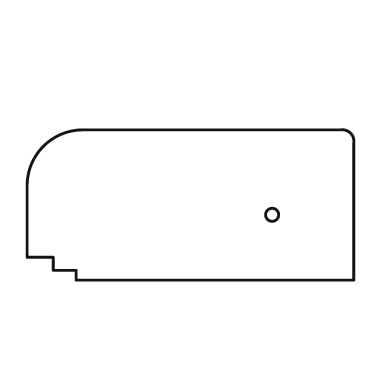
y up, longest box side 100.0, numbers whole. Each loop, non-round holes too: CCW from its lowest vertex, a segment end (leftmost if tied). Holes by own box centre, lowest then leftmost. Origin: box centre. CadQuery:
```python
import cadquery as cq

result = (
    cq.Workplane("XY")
    .moveTo(-35.0, -23.0)
    .lineTo(50.0, -23.0)
    .lineTo(50.0, 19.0)
    .threePointArc((49.0, 22.0), (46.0, 23.0))
    .lineTo(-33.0, 23.0)
    .threePointArc((-45.0, 18.0), (-50.0, 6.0))
    .lineTo(-50.0, -16.0)
    .lineTo(-42.0, -16.0)
    .lineTo(-42.0, -20.0)
    .lineTo(-35.0, -20.0)
    .close()
    .moveTo(25.0, -3.0)
    .circle(2.0)
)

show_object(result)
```